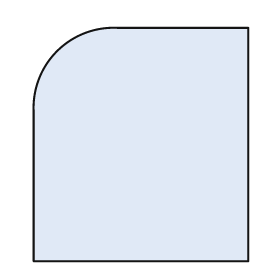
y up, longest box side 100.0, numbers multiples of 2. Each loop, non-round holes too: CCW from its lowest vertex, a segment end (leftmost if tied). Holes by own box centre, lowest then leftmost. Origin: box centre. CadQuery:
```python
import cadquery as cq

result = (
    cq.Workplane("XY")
    .moveTo(-46.0, -50.0)
    .lineTo(46.0, -50.0)
    .lineTo(46.0, 50.0)
    .lineTo(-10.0, 50.0)
    .threePointArc((-36.0, 40.0), (-46.0, 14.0))
    .close()
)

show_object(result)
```